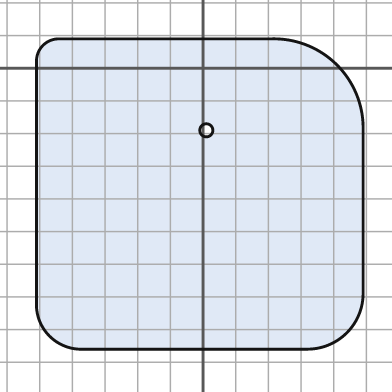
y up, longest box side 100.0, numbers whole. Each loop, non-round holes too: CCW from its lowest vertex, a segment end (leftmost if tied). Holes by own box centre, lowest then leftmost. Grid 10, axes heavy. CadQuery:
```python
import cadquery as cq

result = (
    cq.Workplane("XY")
    .moveTo(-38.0, -86.0)
    .lineTo(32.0, -86.0)
    .threePointArc((44.0, -81.0), (49.0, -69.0))
    .lineTo(49.0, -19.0)
    .threePointArc((41.0, 1.0), (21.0, 9.0))
    .lineTo(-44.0, 9.0)
    .threePointArc((-49.0, 7.0), (-51.0, 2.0))
    .lineTo(-51.0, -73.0)
    .threePointArc((-47.0, -82.0), (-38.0, -86.0))
    .close()
    .moveTo(1.0, -19.0)
    .circle(2.0)
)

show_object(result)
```